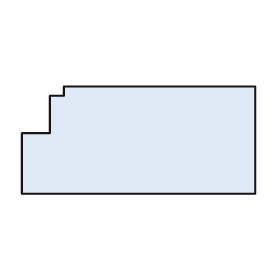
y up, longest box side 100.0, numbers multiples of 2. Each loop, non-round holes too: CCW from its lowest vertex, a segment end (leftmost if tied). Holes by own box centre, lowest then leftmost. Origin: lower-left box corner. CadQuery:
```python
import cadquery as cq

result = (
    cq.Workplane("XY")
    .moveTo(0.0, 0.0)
    .lineTo(100.0, 0.0)
    .lineTo(100.0, 46.0)
    .lineTo(18.0, 46.0)
    .lineTo(18.0, 42.0)
    .lineTo(12.0, 42.0)
    .lineTo(12.0, 26.0)
    .lineTo(0.0, 26.0)
    .close()
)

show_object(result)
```